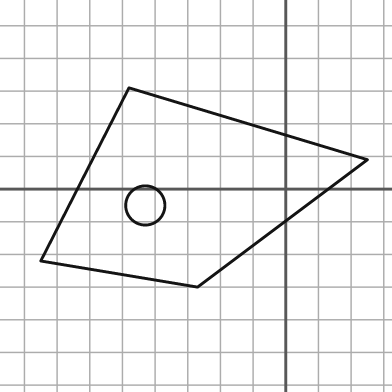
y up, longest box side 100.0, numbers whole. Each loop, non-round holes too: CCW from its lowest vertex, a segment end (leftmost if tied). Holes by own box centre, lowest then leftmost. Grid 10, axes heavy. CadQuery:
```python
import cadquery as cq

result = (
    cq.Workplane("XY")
    .moveTo(-27.0, -30.0)
    .lineTo(25.0, 9.0)
    .lineTo(-48.0, 31.0)
    .lineTo(-75.0, -22.0)
    .close()
    .moveTo(-43.0, -5.0)
    .circle(6.0)
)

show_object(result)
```